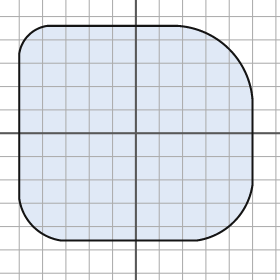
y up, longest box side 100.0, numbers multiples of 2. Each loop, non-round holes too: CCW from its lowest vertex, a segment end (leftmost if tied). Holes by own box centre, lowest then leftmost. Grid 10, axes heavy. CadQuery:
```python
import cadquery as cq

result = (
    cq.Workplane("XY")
    .moveTo(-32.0, -46.0)
    .lineTo(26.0, -46.0)
    .threePointArc((42.0, -38.0), (50.0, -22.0))
    .lineTo(50.0, 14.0)
    .threePointArc((40.0, 36.0), (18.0, 46.0))
    .lineTo(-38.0, 46.0)
    .threePointArc((-46.0, 42.0), (-50.0, 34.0))
    .lineTo(-50.0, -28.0)
    .threePointArc((-44.0, -40.0), (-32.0, -46.0))
    .close()
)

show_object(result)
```